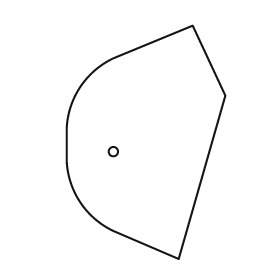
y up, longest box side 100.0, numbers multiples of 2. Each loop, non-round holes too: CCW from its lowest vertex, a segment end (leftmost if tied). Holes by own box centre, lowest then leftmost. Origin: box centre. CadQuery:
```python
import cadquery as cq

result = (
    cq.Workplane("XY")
    .moveTo(14.0, -50.0)
    .lineTo(34.0, 20.0)
    .lineTo(20.0, 50.0)
    .lineTo(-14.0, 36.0)
    .threePointArc((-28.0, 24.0), (-34.0, 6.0))
    .lineTo(-34.0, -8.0)
    .threePointArc((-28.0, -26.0), (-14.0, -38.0))
    .close()
    .moveTo(-14.0, -4.0)
    .circle(2.0)
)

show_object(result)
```